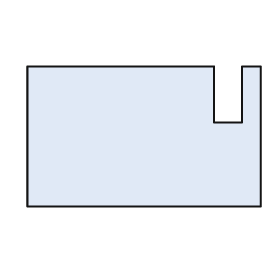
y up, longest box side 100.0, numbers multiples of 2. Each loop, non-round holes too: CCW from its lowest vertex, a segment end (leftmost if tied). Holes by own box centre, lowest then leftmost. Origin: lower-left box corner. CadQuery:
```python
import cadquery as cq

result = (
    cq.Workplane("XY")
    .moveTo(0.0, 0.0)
    .lineTo(100.0, 0.0)
    .lineTo(100.0, 60.0)
    .lineTo(92.0, 60.0)
    .lineTo(92.0, 36.0)
    .lineTo(80.0, 36.0)
    .lineTo(80.0, 60.0)
    .lineTo(0.0, 60.0)
    .close()
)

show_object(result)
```